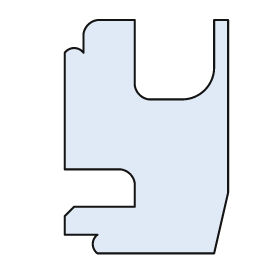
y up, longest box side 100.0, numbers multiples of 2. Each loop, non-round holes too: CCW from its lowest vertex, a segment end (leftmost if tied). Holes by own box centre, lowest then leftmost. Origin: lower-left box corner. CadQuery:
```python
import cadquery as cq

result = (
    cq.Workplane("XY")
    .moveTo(14.0, 0.0)
    .lineTo(64.0, 0.0)
    .lineTo(70.0, 26.0)
    .lineTo(70.0, 100.0)
    .lineTo(64.0, 100.0)
    .lineTo(64.0, 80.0)
    .threePointArc((60.0, 70.0), (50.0, 66.0))
    .lineTo(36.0, 66.0)
    .threePointArc((32.0, 68.0), (30.0, 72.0))
    .lineTo(30.0, 100.0)
    .lineTo(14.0, 100.0)
    .threePointArc((10.0, 98.0), (8.0, 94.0))
    .lineTo(8.0, 86.0)
    .threePointArc((4.0, 88.0), (0.0, 86.0))
    .lineTo(0.0, 36.0)
    .lineTo(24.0, 36.0)
    .threePointArc((28.0, 34.0), (30.0, 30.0))
    .lineTo(30.0, 20.0)
    .lineTo(4.0, 20.0)
    .lineTo(0.0, 16.0)
    .lineTo(0.0, 8.0)
    .lineTo(14.0, 8.0)
    .threePointArc((12.0, 4.0), (14.0, 0.0))
    .close()
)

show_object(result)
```